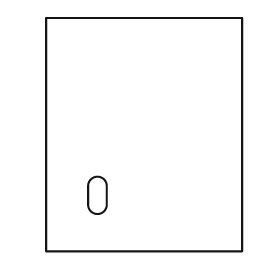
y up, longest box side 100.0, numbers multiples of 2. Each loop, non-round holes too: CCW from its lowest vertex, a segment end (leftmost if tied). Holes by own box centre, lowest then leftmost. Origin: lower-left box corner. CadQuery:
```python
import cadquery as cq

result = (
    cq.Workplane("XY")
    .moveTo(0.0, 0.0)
    .lineTo(84.0, 0.0)
    .lineTo(84.0, 100.0)
    .lineTo(0.0, 100.0)
    .close()
    .moveTo(18.0, 20.0)
    .threePointArc((22.0, 16.0), (26.0, 20.0))
    .lineTo(26.0, 28.0)
    .threePointArc((22.0, 32.0), (18.0, 28.0))
    .close()
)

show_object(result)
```